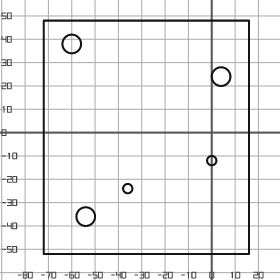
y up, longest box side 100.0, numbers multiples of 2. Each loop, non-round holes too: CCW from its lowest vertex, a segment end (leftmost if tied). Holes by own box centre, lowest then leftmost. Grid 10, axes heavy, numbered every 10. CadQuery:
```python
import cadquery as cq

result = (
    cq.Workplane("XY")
    .moveTo(-72.0, -52.0)
    .lineTo(16.0, -52.0)
    .lineTo(16.0, 48.0)
    .lineTo(-72.0, 48.0)
    .close()
    .moveTo(-54.0, -36.0)
    .circle(4.0)
    .moveTo(-36.0, -24.0)
    .circle(2.0)
    .moveTo(0.0, -12.0)
    .circle(2.0)
    .moveTo(4.0, 24.0)
    .circle(4.0)
    .moveTo(-60.0, 38.0)
    .circle(4.0)
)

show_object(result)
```